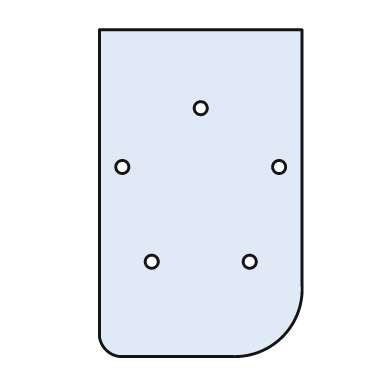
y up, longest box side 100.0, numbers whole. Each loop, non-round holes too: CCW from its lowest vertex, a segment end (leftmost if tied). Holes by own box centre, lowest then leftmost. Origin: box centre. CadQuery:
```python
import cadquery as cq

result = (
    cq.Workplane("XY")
    .moveTo(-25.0, -50.0)
    .lineTo(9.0, -50.0)
    .threePointArc((25.0, -44.0), (31.0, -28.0))
    .lineTo(31.0, 50.0)
    .lineTo(-31.0, 50.0)
    .lineTo(-31.0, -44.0)
    .threePointArc((-29.0, -48.0), (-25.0, -50.0))
    .close()
    .moveTo(-15.0, -21.0)
    .circle(2.0)
    .moveTo(15.0, -21.0)
    .circle(2.0)
    .moveTo(-24.0, 8.0)
    .circle(2.0)
    .moveTo(24.0, 8.0)
    .circle(2.0)
    .moveTo(0.0, 26.0)
    .circle(2.0)
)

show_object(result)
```